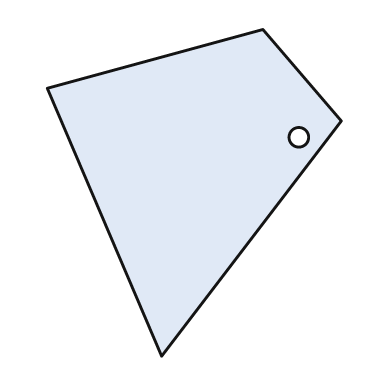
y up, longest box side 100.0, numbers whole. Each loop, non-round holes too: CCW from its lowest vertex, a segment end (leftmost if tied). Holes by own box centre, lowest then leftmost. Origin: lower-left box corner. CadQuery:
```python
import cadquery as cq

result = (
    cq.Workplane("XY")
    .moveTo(35.0, 0.0)
    .lineTo(90.0, 72.0)
    .lineTo(66.0, 100.0)
    .lineTo(0.0, 82.0)
    .close()
    .moveTo(77.0, 67.0)
    .circle(3.0)
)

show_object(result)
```